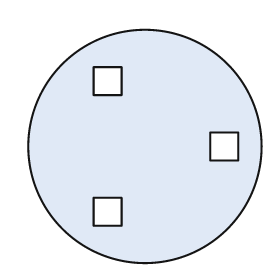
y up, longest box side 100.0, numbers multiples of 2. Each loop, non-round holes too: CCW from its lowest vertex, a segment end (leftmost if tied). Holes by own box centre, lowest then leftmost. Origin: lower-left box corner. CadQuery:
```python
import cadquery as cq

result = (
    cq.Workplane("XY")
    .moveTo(50.0, 50.0)
    .circle(50.0)
    .moveTo(28.0, 16.0)
    .lineTo(40.0, 16.0)
    .lineTo(40.0, 28.0)
    .lineTo(28.0, 28.0)
    .close()
    .moveTo(78.0, 44.0)
    .lineTo(90.0, 44.0)
    .lineTo(90.0, 56.0)
    .lineTo(78.0, 56.0)
    .close()
    .moveTo(28.0, 72.0)
    .lineTo(40.0, 72.0)
    .lineTo(40.0, 84.0)
    .lineTo(28.0, 84.0)
    .close()
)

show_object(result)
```